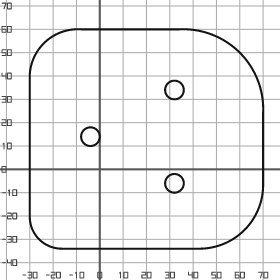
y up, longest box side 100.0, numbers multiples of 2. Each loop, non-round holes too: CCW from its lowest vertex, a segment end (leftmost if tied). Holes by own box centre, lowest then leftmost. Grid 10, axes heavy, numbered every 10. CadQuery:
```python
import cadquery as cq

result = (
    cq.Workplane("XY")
    .moveTo(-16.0, -34.0)
    .lineTo(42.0, -34.0)
    .threePointArc((62.0, -26.0), (70.0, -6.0))
    .lineTo(70.0, 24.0)
    .threePointArc((60.0, 50.0), (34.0, 60.0))
    .lineTo(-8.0, 60.0)
    .threePointArc((-24.0, 54.0), (-30.0, 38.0))
    .lineTo(-30.0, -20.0)
    .threePointArc((-26.0, -30.0), (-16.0, -34.0))
    .close()
    .moveTo(32.0, -6.0)
    .circle(4.0)
    .moveTo(-4.0, 14.0)
    .circle(4.0)
    .moveTo(32.0, 34.0)
    .circle(4.0)
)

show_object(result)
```